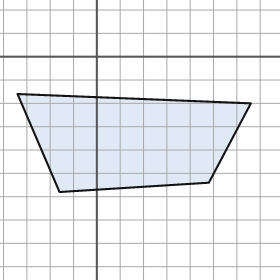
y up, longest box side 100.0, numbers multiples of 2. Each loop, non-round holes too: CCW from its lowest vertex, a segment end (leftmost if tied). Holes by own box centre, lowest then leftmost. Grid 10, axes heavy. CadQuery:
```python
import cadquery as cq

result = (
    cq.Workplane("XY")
    .moveTo(-16.0, -58.0)
    .lineTo(48.0, -54.0)
    .lineTo(66.0, -20.0)
    .lineTo(-34.0, -16.0)
    .close()
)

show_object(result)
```